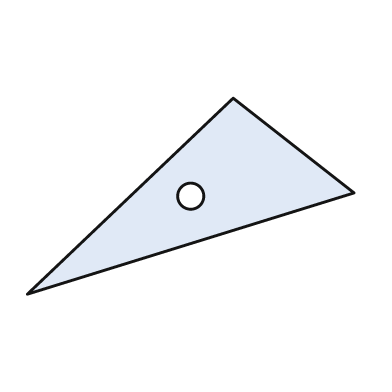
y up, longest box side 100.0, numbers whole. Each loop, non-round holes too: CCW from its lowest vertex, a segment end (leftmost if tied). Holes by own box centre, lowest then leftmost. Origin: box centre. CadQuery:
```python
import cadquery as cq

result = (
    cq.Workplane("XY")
    .moveTo(-50.0, -30.0)
    .lineTo(50.0, 1.0)
    .lineTo(13.0, 30.0)
    .close()
    .moveTo(0.0, 0.0)
    .circle(4.0)
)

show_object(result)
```